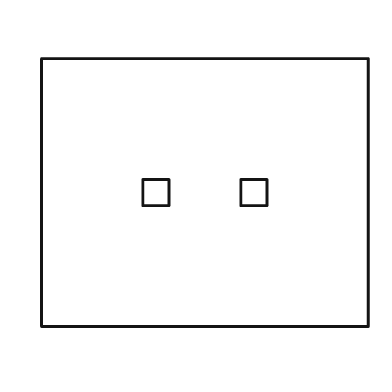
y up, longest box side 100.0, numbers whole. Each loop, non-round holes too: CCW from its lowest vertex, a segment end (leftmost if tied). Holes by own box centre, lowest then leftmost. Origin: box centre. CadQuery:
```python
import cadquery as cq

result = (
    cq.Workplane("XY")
    .moveTo(-50.0, -41.0)
    .lineTo(50.0, -41.0)
    .lineTo(50.0, 41.0)
    .lineTo(-50.0, 41.0)
    .close()
    .moveTo(-19.0, -4.0)
    .lineTo(-11.0, -4.0)
    .lineTo(-11.0, 4.0)
    .lineTo(-19.0, 4.0)
    .close()
    .moveTo(11.0, -4.0)
    .lineTo(19.0, -4.0)
    .lineTo(19.0, 4.0)
    .lineTo(11.0, 4.0)
    .close()
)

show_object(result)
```